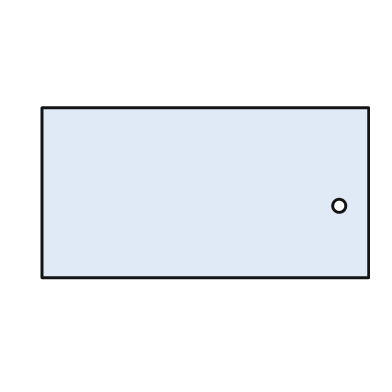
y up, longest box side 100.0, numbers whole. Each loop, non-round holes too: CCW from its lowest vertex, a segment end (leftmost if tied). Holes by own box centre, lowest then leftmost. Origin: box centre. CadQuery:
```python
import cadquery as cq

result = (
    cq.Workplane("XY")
    .moveTo(-50.0, -26.0)
    .lineTo(50.0, -26.0)
    .lineTo(50.0, 26.0)
    .lineTo(-50.0, 26.0)
    .close()
    .moveTo(41.0, -4.0)
    .circle(2.0)
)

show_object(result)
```